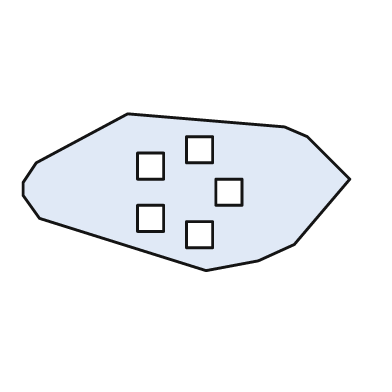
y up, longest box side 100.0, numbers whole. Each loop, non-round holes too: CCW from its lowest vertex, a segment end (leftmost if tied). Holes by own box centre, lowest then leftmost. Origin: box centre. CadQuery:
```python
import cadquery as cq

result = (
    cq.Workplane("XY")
    .moveTo(6.0, -24.0)
    .lineTo(22.0, -21.0)
    .lineTo(33.0, -16.0)
    .lineTo(50.0, 4.0)
    .lineTo(37.0, 17.0)
    .lineTo(30.0, 20.0)
    .lineTo(-18.0, 24.0)
    .lineTo(-46.0, 9.0)
    .lineTo(-50.0, 3.0)
    .lineTo(-50.0, -1.0)
    .lineTo(-45.0, -8.0)
    .close()
    .moveTo(0.0, -17.0)
    .lineTo(8.0, -17.0)
    .lineTo(8.0, -9.0)
    .lineTo(0.0, -9.0)
    .close()
    .moveTo(-15.0, -12.0)
    .lineTo(-7.0, -12.0)
    .lineTo(-7.0, -4.0)
    .lineTo(-15.0, -4.0)
    .close()
    .moveTo(9.0, -4.0)
    .lineTo(17.0, -4.0)
    .lineTo(17.0, 4.0)
    .lineTo(9.0, 4.0)
    .close()
    .moveTo(-15.0, 4.0)
    .lineTo(-7.0, 4.0)
    .lineTo(-7.0, 12.0)
    .lineTo(-15.0, 12.0)
    .close()
    .moveTo(0.0, 9.0)
    .lineTo(8.0, 9.0)
    .lineTo(8.0, 17.0)
    .lineTo(0.0, 17.0)
    .close()
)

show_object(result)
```